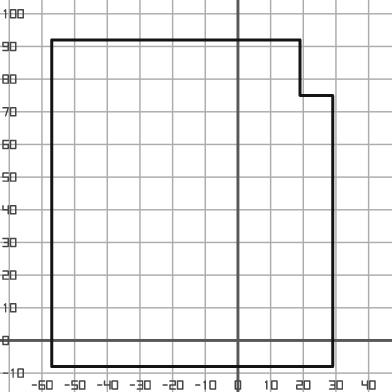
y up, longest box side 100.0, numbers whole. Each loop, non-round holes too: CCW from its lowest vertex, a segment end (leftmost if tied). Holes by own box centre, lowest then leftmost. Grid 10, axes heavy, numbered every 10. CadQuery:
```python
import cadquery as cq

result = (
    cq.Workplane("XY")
    .moveTo(-57.0, -8.0)
    .lineTo(29.0, -8.0)
    .lineTo(29.0, 75.0)
    .lineTo(19.0, 75.0)
    .lineTo(19.0, 92.0)
    .lineTo(-57.0, 92.0)
    .close()
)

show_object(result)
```